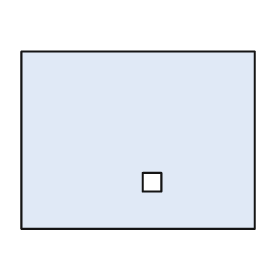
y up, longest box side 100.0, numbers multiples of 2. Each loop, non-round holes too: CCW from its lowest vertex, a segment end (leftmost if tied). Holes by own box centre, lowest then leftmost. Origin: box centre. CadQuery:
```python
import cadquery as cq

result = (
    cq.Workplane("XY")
    .moveTo(-50.0, -38.0)
    .lineTo(50.0, -38.0)
    .lineTo(50.0, 38.0)
    .lineTo(-50.0, 38.0)
    .close()
    .moveTo(2.0, -22.0)
    .lineTo(10.0, -22.0)
    .lineTo(10.0, -14.0)
    .lineTo(2.0, -14.0)
    .close()
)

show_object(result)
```